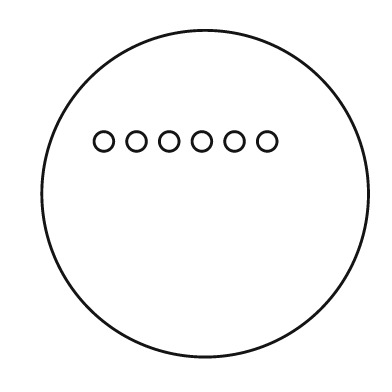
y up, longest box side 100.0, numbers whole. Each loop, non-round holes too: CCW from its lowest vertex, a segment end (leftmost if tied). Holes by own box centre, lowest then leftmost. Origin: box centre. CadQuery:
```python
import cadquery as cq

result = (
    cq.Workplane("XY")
    .moveTo(0.0, 0.0)
    .circle(50.0)
    .moveTo(-31.0, 16.0)
    .circle(3.0)
    .moveTo(-21.0, 16.0)
    .circle(3.0)
    .moveTo(-11.0, 16.0)
    .circle(3.0)
    .moveTo(-1.0, 16.0)
    .circle(3.0)
    .moveTo(9.0, 16.0)
    .circle(3.0)
    .moveTo(19.0, 16.0)
    .circle(3.0)
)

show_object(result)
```